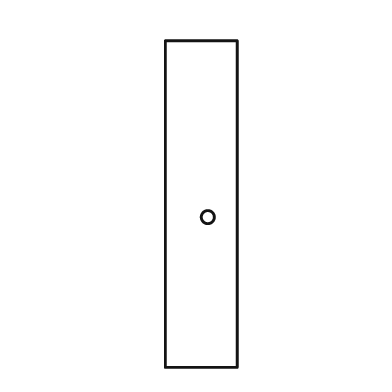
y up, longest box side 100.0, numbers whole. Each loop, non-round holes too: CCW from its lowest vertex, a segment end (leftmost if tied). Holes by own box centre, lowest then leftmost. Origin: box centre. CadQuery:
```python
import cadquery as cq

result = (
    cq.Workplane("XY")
    .moveTo(-11.0, -50.0)
    .lineTo(11.0, -50.0)
    .lineTo(11.0, 50.0)
    .lineTo(-11.0, 50.0)
    .close()
    .moveTo(2.0, -4.0)
    .circle(2.0)
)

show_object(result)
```